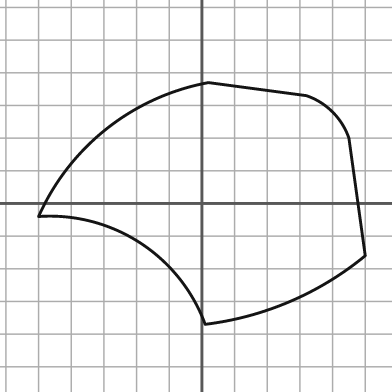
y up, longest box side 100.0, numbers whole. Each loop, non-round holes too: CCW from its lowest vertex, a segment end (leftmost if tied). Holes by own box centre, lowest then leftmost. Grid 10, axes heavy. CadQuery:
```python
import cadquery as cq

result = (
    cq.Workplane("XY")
    .moveTo(1.0, -37.0)
    .threePointArc((27.0, -30.0), (50.0, -16.0))
    .lineTo(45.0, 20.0)
    .threePointArc((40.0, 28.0), (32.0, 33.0))
    .lineTo(2.0, 37.0)
    .threePointArc((-29.0, 23.0), (-50.0, -4.0))
    .threePointArc((-19.0, -12.0), (1.0, -37.0))
    .close()
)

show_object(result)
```